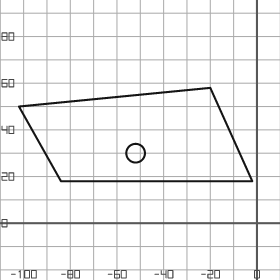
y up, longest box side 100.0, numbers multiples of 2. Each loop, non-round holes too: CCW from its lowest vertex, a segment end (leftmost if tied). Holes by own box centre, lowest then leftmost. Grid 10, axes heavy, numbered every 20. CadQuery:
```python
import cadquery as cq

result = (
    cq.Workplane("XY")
    .moveTo(-84.0, 18.0)
    .lineTo(-2.0, 18.0)
    .lineTo(-20.0, 58.0)
    .lineTo(-102.0, 50.0)
    .close()
    .moveTo(-52.0, 30.0)
    .circle(4.0)
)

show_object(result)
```